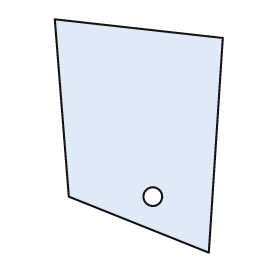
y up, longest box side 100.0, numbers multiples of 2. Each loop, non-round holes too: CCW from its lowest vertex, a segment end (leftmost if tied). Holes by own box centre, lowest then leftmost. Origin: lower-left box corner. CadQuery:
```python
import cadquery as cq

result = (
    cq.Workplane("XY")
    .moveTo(66.0, 0.0)
    .lineTo(72.0, 92.0)
    .lineTo(0.0, 100.0)
    .lineTo(6.0, 24.0)
    .close()
    .moveTo(42.0, 24.0)
    .circle(4.0)
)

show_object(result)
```